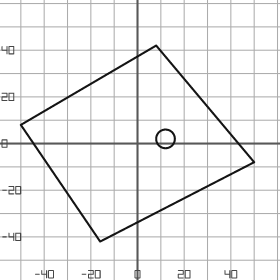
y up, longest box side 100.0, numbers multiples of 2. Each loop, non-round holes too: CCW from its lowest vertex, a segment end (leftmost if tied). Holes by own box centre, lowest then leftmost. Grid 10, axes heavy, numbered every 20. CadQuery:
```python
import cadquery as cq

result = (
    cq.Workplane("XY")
    .moveTo(-16.0, -42.0)
    .lineTo(50.0, -8.0)
    .lineTo(8.0, 42.0)
    .lineTo(-50.0, 8.0)
    .close()
    .moveTo(12.0, 2.0)
    .circle(4.0)
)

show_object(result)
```